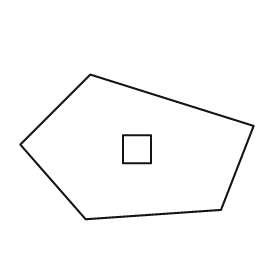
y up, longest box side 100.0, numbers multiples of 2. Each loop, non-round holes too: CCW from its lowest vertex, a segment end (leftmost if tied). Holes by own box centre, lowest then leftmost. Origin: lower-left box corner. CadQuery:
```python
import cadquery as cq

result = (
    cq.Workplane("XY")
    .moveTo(28.0, 0.0)
    .lineTo(86.0, 4.0)
    .lineTo(100.0, 40.0)
    .lineTo(30.0, 62.0)
    .lineTo(0.0, 32.0)
    .close()
    .moveTo(44.0, 24.0)
    .lineTo(56.0, 24.0)
    .lineTo(56.0, 36.0)
    .lineTo(44.0, 36.0)
    .close()
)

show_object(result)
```